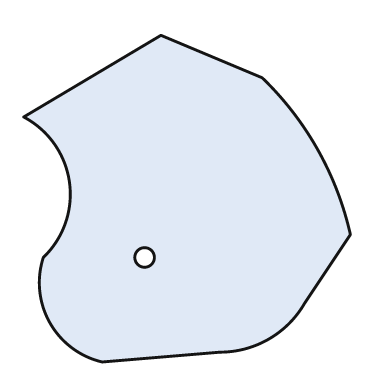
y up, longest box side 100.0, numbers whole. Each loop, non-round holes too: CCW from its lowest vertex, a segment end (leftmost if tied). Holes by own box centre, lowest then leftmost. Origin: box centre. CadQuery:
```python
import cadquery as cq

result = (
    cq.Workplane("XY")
    .moveTo(-26.0, -50.0)
    .lineTo(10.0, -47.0)
    .threePointArc((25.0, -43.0), (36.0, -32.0))
    .lineTo(50.0, -11.0)
    .threePointArc((40.0, 15.0), (23.0, 37.0))
    .lineTo(-8.0, 50.0)
    .lineTo(-50.0, 25.0)
    .threePointArc((-36.0, 5.0), (-44.0, -18.0))
    .threePointArc((-42.0, -38.0), (-26.0, -50.0))
    .close()
    .moveTo(-13.0, -18.0)
    .circle(3.0)
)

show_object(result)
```